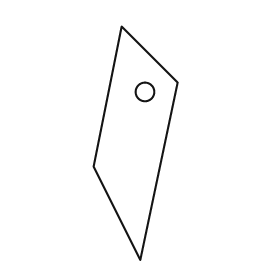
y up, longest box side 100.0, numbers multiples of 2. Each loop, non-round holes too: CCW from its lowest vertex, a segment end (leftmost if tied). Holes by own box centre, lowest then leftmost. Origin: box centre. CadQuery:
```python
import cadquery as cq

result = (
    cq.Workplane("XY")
    .moveTo(2.0, -50.0)
    .lineTo(18.0, 26.0)
    .lineTo(-6.0, 50.0)
    .lineTo(-18.0, -10.0)
    .close()
    .moveTo(4.0, 22.0)
    .circle(4.0)
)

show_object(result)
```